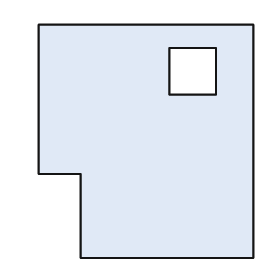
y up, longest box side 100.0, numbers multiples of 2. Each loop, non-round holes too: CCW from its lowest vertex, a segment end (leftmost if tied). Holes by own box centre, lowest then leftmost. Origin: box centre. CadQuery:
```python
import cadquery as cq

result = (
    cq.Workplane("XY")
    .moveTo(-28.0, -50.0)
    .lineTo(46.0, -50.0)
    .lineTo(46.0, 50.0)
    .lineTo(-46.0, 50.0)
    .lineTo(-46.0, -14.0)
    .lineTo(-28.0, -14.0)
    .close()
    .moveTo(10.0, 20.0)
    .lineTo(30.0, 20.0)
    .lineTo(30.0, 40.0)
    .lineTo(10.0, 40.0)
    .close()
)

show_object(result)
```